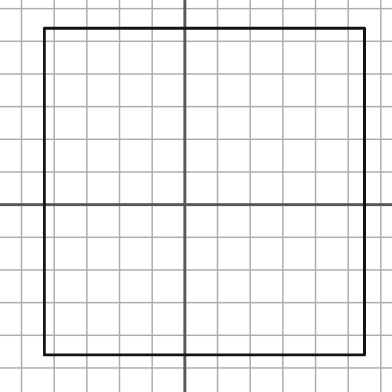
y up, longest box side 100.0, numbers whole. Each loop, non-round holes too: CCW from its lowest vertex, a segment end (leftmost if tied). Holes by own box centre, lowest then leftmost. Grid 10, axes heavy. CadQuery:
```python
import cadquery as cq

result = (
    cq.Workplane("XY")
    .moveTo(-43.0, -46.0)
    .lineTo(55.0, -46.0)
    .lineTo(55.0, 54.0)
    .lineTo(-43.0, 54.0)
    .close()
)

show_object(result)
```